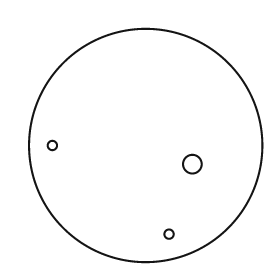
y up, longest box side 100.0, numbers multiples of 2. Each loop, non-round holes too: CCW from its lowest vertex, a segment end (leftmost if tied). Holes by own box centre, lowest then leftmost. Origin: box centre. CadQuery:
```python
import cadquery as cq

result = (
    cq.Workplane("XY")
    .moveTo(0.0, 0.0)
    .circle(50.0)
    .moveTo(10.0, -38.0)
    .circle(2.0)
    .moveTo(20.0, -8.0)
    .circle(4.0)
    .moveTo(-40.0, 0.0)
    .circle(2.0)
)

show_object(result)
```